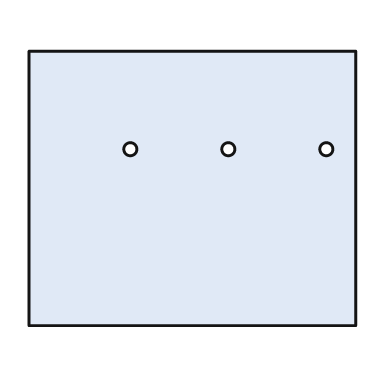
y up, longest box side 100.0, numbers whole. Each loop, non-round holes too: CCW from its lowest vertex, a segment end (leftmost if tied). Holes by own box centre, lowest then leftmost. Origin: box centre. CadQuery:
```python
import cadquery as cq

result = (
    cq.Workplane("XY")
    .moveTo(-50.0, -42.0)
    .lineTo(50.0, -42.0)
    .lineTo(50.0, 42.0)
    .lineTo(-50.0, 42.0)
    .close()
    .moveTo(-19.0, 12.0)
    .circle(2.0)
    .moveTo(11.0, 12.0)
    .circle(2.0)
    .moveTo(41.0, 12.0)
    .circle(2.0)
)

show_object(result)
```